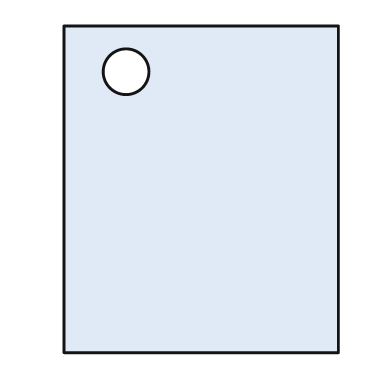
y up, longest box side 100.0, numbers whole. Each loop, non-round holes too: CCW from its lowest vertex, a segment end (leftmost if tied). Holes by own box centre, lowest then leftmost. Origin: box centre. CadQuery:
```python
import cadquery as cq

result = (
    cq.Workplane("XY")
    .moveTo(-42.0, -50.0)
    .lineTo(42.0, -50.0)
    .lineTo(42.0, 50.0)
    .lineTo(-42.0, 50.0)
    .close()
    .moveTo(-23.0, 36.0)
    .circle(7.0)
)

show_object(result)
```